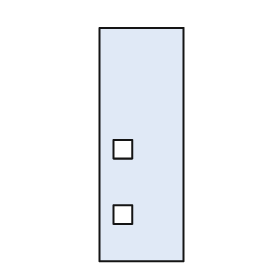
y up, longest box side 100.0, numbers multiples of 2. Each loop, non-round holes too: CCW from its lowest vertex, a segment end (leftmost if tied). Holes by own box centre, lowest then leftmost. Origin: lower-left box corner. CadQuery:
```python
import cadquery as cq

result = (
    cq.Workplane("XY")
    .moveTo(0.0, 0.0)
    .lineTo(36.0, 0.0)
    .lineTo(36.0, 100.0)
    .lineTo(0.0, 100.0)
    .close()
    .moveTo(6.0, 16.0)
    .lineTo(14.0, 16.0)
    .lineTo(14.0, 24.0)
    .lineTo(6.0, 24.0)
    .close()
    .moveTo(6.0, 44.0)
    .lineTo(14.0, 44.0)
    .lineTo(14.0, 52.0)
    .lineTo(6.0, 52.0)
    .close()
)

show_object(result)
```